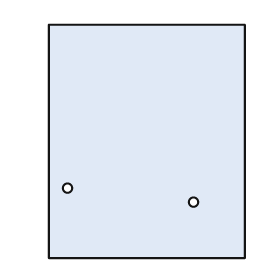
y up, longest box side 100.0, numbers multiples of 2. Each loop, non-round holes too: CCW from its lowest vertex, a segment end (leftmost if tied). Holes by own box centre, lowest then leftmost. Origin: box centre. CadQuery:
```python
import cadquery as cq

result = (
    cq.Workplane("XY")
    .moveTo(-42.0, -50.0)
    .lineTo(42.0, -50.0)
    .lineTo(42.0, 50.0)
    .lineTo(-42.0, 50.0)
    .close()
    .moveTo(20.0, -26.0)
    .circle(2.0)
    .moveTo(-34.0, -20.0)
    .circle(2.0)
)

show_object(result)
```